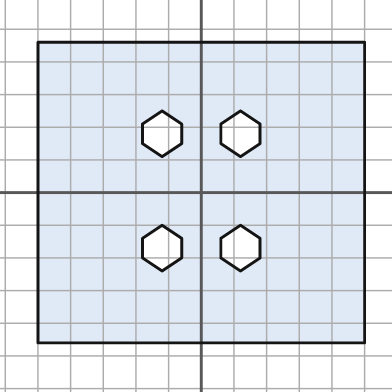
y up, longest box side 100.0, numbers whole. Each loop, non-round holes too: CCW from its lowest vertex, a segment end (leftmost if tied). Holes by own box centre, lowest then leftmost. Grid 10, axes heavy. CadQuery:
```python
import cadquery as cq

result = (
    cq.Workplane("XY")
    .moveTo(-50.0, -46.0)
    .lineTo(50.0, -46.0)
    .lineTo(50.0, 46.0)
    .lineTo(-50.0, 46.0)
    .close()
    .moveTo(-12.0, -24.0)
    .lineTo(-6.0, -20.0)
    .lineTo(-6.0, -14.0)
    .lineTo(-12.0, -10.0)
    .lineTo(-18.0, -14.0)
    .lineTo(-18.0, -20.0)
    .close()
    .moveTo(12.0, -24.0)
    .lineTo(18.0, -20.0)
    .lineTo(18.0, -14.0)
    .lineTo(12.0, -10.0)
    .lineTo(6.0, -14.0)
    .lineTo(6.0, -20.0)
    .close()
    .moveTo(-12.0, 11.0)
    .lineTo(-6.0, 15.0)
    .lineTo(-6.0, 21.0)
    .lineTo(-12.0, 25.0)
    .lineTo(-18.0, 21.0)
    .lineTo(-18.0, 15.0)
    .close()
    .moveTo(12.0, 11.0)
    .lineTo(18.0, 15.0)
    .lineTo(18.0, 21.0)
    .lineTo(12.0, 25.0)
    .lineTo(6.0, 21.0)
    .lineTo(6.0, 15.0)
    .close()
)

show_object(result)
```